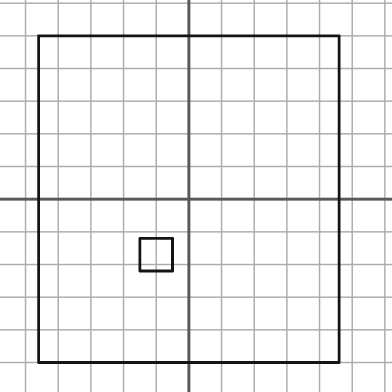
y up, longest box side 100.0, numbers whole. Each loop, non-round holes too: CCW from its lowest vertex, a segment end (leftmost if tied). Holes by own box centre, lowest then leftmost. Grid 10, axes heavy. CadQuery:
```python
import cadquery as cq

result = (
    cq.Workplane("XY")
    .moveTo(-46.0, -50.0)
    .lineTo(46.0, -50.0)
    .lineTo(46.0, 50.0)
    .lineTo(-46.0, 50.0)
    .close()
    .moveTo(-15.0, -22.0)
    .lineTo(-5.0, -22.0)
    .lineTo(-5.0, -12.0)
    .lineTo(-15.0, -12.0)
    .close()
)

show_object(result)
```